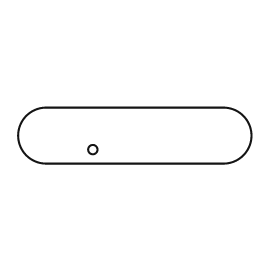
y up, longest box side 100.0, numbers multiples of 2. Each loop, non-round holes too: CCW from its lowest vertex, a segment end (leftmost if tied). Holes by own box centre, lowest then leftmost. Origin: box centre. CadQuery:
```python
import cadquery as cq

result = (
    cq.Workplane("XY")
    .moveTo(-38.0, -12.0)
    .lineTo(38.0, -12.0)
    .threePointArc((50.0, 0.0), (38.0, 12.0))
    .lineTo(-38.0, 12.0)
    .threePointArc((-50.0, 0.0), (-38.0, -12.0))
    .close()
    .moveTo(-18.0, -6.0)
    .circle(2.0)
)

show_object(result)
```